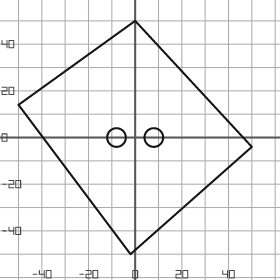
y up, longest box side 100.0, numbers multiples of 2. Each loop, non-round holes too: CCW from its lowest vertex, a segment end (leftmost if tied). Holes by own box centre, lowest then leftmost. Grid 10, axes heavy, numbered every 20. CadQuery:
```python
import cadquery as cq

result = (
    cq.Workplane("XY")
    .moveTo(-2.0, -50.0)
    .lineTo(50.0, -4.0)
    .lineTo(0.0, 50.0)
    .lineTo(-50.0, 14.0)
    .close()
    .moveTo(-8.0, 0.0)
    .circle(4.0)
    .moveTo(8.0, 0.0)
    .circle(4.0)
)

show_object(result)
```